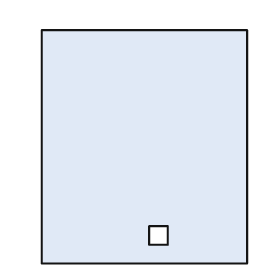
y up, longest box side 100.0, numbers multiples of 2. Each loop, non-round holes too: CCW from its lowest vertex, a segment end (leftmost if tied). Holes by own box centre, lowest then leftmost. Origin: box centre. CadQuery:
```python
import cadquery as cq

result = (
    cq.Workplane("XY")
    .moveTo(-44.0, -50.0)
    .lineTo(44.0, -50.0)
    .lineTo(44.0, 50.0)
    .lineTo(-44.0, 50.0)
    .close()
    .moveTo(2.0, -42.0)
    .lineTo(10.0, -42.0)
    .lineTo(10.0, -34.0)
    .lineTo(2.0, -34.0)
    .close()
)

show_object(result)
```